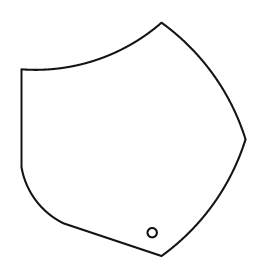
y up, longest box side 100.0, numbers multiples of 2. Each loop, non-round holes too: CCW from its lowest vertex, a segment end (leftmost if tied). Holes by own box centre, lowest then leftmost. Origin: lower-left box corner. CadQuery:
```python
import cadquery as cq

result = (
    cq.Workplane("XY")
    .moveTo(60.0, 0.0)
    .threePointArc((82.0, 22.0), (96.0, 50.0))
    .threePointArc((82.0, 78.0), (60.0, 100.0))
    .threePointArc((32.0, 84.0), (0.0, 80.0))
    .lineTo(0.0, 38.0)
    .threePointArc((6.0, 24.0), (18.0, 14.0))
    .close()
    .moveTo(56.0, 10.0)
    .circle(2.0)
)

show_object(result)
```